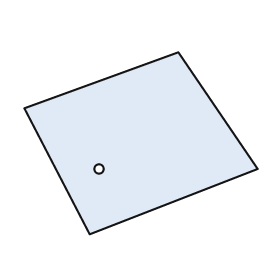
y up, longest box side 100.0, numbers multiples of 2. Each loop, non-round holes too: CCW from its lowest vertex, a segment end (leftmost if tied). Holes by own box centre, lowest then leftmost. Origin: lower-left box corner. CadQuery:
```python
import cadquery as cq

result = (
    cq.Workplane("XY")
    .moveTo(28.0, 0.0)
    .lineTo(100.0, 28.0)
    .lineTo(66.0, 78.0)
    .lineTo(0.0, 54.0)
    .close()
    .moveTo(32.0, 28.0)
    .circle(2.0)
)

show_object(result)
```